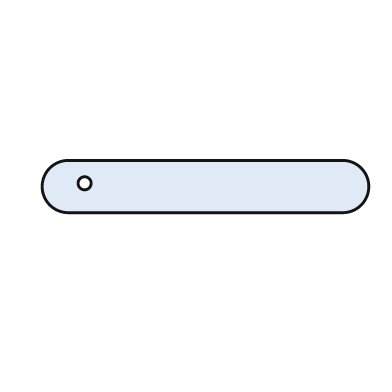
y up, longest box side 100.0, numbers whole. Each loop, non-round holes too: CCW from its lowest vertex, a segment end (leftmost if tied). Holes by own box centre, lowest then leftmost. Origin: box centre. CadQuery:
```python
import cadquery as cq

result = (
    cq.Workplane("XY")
    .moveTo(-42.0, -8.0)
    .lineTo(42.0, -8.0)
    .threePointArc((50.0, 0.0), (42.0, 8.0))
    .lineTo(-42.0, 8.0)
    .threePointArc((-50.0, 0.0), (-42.0, -8.0))
    .close()
    .moveTo(-37.0, 1.0)
    .circle(2.0)
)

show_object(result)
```